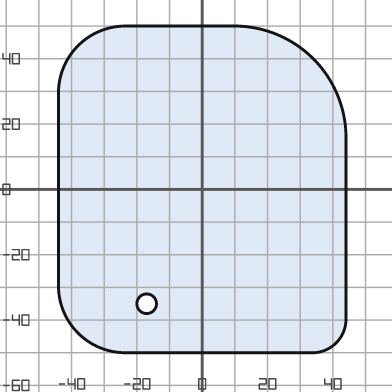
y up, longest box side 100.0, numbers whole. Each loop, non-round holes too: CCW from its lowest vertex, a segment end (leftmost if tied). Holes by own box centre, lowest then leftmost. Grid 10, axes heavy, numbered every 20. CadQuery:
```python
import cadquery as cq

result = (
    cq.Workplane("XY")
    .moveTo(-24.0, -50.0)
    .lineTo(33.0, -50.0)
    .threePointArc((41.0, -47.0), (44.0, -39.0))
    .lineTo(44.0, 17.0)
    .threePointArc((34.0, 40.0), (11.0, 50.0))
    .lineTo(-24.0, 50.0)
    .threePointArc((-38.0, 44.0), (-44.0, 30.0))
    .lineTo(-44.0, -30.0)
    .threePointArc((-38.0, -44.0), (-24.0, -50.0))
    .close()
    .moveTo(-17.0, -35.0)
    .circle(3.0)
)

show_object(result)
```